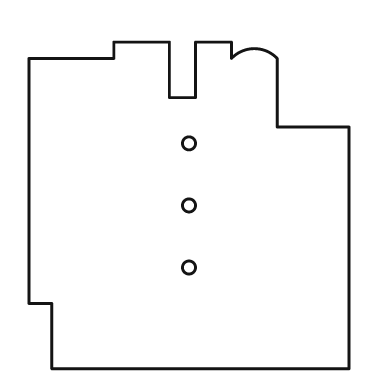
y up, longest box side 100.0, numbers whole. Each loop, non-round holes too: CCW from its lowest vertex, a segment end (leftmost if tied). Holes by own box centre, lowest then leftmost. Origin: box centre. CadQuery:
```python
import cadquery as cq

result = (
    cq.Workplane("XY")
    .moveTo(-42.0, -50.0)
    .lineTo(49.0, -50.0)
    .lineTo(49.0, 24.0)
    .lineTo(27.0, 24.0)
    .lineTo(27.0, 45.0)
    .threePointArc((20.0, 48.0), (13.0, 45.0))
    .lineTo(13.0, 50.0)
    .lineTo(2.0, 50.0)
    .lineTo(2.0, 33.0)
    .lineTo(-6.0, 33.0)
    .lineTo(-6.0, 50.0)
    .lineTo(-23.0, 50.0)
    .lineTo(-23.0, 45.0)
    .lineTo(-49.0, 45.0)
    .lineTo(-49.0, -30.0)
    .lineTo(-42.0, -30.0)
    .close()
    .moveTo(0.0, -19.0)
    .circle(2.0)
    .moveTo(0.0, 0.0)
    .circle(2.0)
    .moveTo(0.0, 19.0)
    .circle(2.0)
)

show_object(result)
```